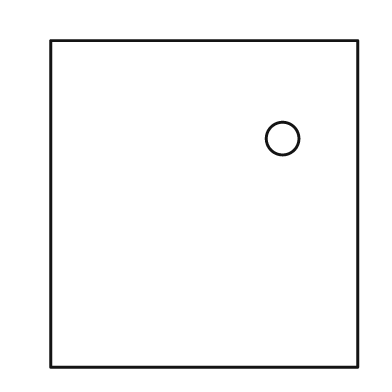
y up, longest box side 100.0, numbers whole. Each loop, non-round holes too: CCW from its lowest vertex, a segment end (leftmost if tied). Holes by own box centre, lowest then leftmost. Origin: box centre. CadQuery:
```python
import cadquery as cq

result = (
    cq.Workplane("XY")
    .moveTo(-47.0, -50.0)
    .lineTo(47.0, -50.0)
    .lineTo(47.0, 50.0)
    .lineTo(-47.0, 50.0)
    .close()
    .moveTo(24.0, 20.0)
    .circle(5.0)
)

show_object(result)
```